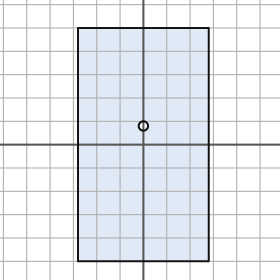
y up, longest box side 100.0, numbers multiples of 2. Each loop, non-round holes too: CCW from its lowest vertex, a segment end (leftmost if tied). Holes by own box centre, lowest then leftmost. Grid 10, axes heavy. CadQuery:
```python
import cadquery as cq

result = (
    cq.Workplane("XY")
    .moveTo(-28.0, -50.0)
    .lineTo(28.0, -50.0)
    .lineTo(28.0, 50.0)
    .lineTo(-28.0, 50.0)
    .close()
    .moveTo(0.0, 8.0)
    .circle(2.0)
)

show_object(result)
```